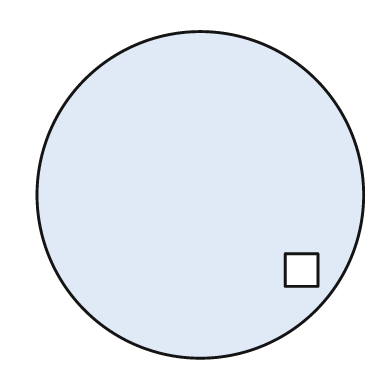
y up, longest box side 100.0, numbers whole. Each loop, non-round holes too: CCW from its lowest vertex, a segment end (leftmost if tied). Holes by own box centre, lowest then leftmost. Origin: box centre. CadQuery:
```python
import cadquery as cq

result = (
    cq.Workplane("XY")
    .moveTo(0.0, 0.0)
    .circle(50.0)
    .moveTo(26.0, -28.0)
    .lineTo(36.0, -28.0)
    .lineTo(36.0, -18.0)
    .lineTo(26.0, -18.0)
    .close()
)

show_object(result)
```